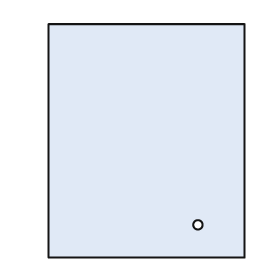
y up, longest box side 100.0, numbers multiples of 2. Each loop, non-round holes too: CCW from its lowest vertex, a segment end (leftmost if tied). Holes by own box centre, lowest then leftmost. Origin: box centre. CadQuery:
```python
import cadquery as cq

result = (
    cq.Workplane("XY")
    .moveTo(-42.0, -50.0)
    .lineTo(42.0, -50.0)
    .lineTo(42.0, 50.0)
    .lineTo(-42.0, 50.0)
    .close()
    .moveTo(22.0, -36.0)
    .circle(2.0)
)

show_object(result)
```